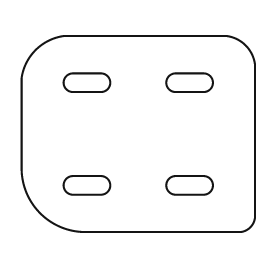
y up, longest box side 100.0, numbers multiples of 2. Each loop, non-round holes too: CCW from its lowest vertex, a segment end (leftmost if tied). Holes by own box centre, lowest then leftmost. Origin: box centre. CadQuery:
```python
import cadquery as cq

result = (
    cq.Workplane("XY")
    .moveTo(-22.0, -42.0)
    .lineTo(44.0, -42.0)
    .threePointArc((48.0, -40.0), (50.0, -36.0))
    .lineTo(50.0, 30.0)
    .threePointArc((46.0, 38.0), (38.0, 42.0))
    .lineTo(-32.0, 42.0)
    .threePointArc((-44.0, 36.0), (-50.0, 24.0))
    .lineTo(-50.0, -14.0)
    .threePointArc((-42.0, -34.0), (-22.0, -42.0))
    .close()
    .moveTo(-28.0, -26.0)
    .lineTo(-16.0, -26.0)
    .threePointArc((-12.0, -22.0), (-16.0, -18.0))
    .lineTo(-28.0, -18.0)
    .threePointArc((-32.0, -22.0), (-28.0, -26.0))
    .close()
    .moveTo(16.0, -26.0)
    .lineTo(28.0, -26.0)
    .threePointArc((32.0, -22.0), (28.0, -18.0))
    .lineTo(16.0, -18.0)
    .threePointArc((12.0, -22.0), (16.0, -26.0))
    .close()
    .moveTo(-28.0, 18.0)
    .lineTo(-16.0, 18.0)
    .threePointArc((-12.0, 22.0), (-16.0, 26.0))
    .lineTo(-28.0, 26.0)
    .threePointArc((-32.0, 22.0), (-28.0, 18.0))
    .close()
    .moveTo(16.0, 18.0)
    .lineTo(28.0, 18.0)
    .threePointArc((32.0, 22.0), (28.0, 26.0))
    .lineTo(16.0, 26.0)
    .threePointArc((12.0, 22.0), (16.0, 18.0))
    .close()
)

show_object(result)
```